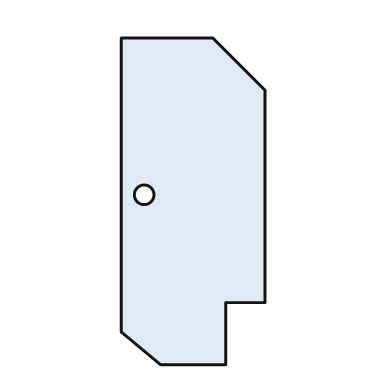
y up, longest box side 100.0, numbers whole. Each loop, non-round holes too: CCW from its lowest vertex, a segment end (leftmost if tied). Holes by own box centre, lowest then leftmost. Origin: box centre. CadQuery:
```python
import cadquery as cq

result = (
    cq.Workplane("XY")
    .moveTo(-10.0, -50.0)
    .lineTo(10.0, -50.0)
    .lineTo(10.0, -31.0)
    .lineTo(22.0, -31.0)
    .lineTo(22.0, 34.0)
    .lineTo(6.0, 50.0)
    .lineTo(-22.0, 50.0)
    .lineTo(-22.0, -40.0)
    .close()
    .moveTo(-15.0, 2.0)
    .circle(3.0)
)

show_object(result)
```